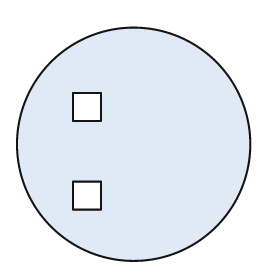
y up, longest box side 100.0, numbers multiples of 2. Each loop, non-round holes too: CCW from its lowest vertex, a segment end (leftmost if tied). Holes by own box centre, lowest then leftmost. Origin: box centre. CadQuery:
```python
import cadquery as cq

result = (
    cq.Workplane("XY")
    .moveTo(0.0, 0.0)
    .circle(50.0)
    .moveTo(-26.0, -28.0)
    .lineTo(-14.0, -28.0)
    .lineTo(-14.0, -16.0)
    .lineTo(-26.0, -16.0)
    .close()
    .moveTo(-26.0, 10.0)
    .lineTo(-14.0, 10.0)
    .lineTo(-14.0, 22.0)
    .lineTo(-26.0, 22.0)
    .close()
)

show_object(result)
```